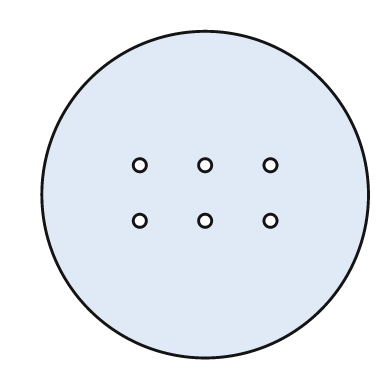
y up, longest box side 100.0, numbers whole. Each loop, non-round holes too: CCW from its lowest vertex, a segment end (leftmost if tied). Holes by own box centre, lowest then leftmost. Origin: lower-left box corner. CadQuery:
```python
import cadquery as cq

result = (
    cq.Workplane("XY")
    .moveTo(50.0, 50.0)
    .circle(50.0)
    .moveTo(30.0, 42.0)
    .circle(2.0)
    .moveTo(50.0, 42.0)
    .circle(2.0)
    .moveTo(70.0, 42.0)
    .circle(2.0)
    .moveTo(30.0, 59.0)
    .circle(2.0)
    .moveTo(50.0, 59.0)
    .circle(2.0)
    .moveTo(70.0, 59.0)
    .circle(2.0)
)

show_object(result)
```